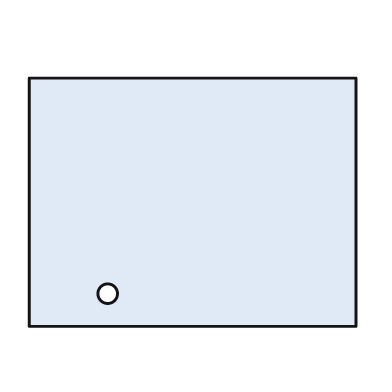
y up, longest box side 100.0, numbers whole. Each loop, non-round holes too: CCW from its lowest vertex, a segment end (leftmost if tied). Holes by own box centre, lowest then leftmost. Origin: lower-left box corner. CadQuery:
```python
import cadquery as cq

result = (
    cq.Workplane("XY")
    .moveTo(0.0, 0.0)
    .lineTo(100.0, 0.0)
    .lineTo(100.0, 76.0)
    .lineTo(0.0, 76.0)
    .close()
    .moveTo(24.0, 10.0)
    .circle(3.0)
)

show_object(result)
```